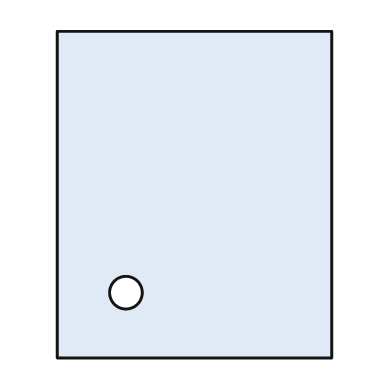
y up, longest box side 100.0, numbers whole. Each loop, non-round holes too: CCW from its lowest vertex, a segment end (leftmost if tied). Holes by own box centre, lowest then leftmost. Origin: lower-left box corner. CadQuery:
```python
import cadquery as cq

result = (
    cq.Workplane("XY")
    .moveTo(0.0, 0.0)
    .lineTo(84.0, 0.0)
    .lineTo(84.0, 100.0)
    .lineTo(0.0, 100.0)
    .close()
    .moveTo(21.0, 20.0)
    .circle(5.0)
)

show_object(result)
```